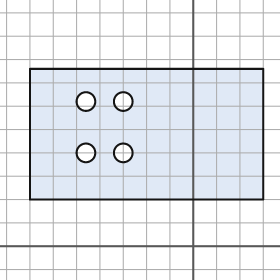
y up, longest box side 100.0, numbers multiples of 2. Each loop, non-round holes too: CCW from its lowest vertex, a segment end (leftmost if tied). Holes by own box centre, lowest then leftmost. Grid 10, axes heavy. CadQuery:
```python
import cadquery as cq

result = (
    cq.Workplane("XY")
    .moveTo(-70.0, 20.0)
    .lineTo(30.0, 20.0)
    .lineTo(30.0, 76.0)
    .lineTo(-70.0, 76.0)
    .close()
    .moveTo(-46.0, 40.0)
    .circle(4.0)
    .moveTo(-30.0, 40.0)
    .circle(4.0)
    .moveTo(-46.0, 62.0)
    .circle(4.0)
    .moveTo(-30.0, 62.0)
    .circle(4.0)
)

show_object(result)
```